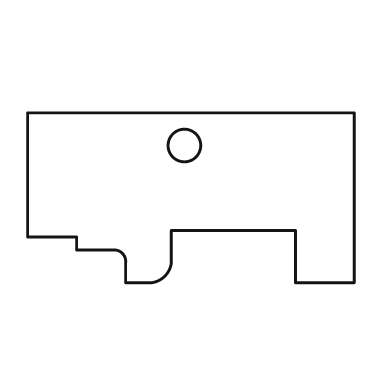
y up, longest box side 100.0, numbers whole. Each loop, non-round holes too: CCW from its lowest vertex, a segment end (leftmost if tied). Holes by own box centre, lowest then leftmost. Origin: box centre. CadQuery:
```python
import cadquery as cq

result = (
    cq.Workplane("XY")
    .moveTo(-20.0, -26.0)
    .lineTo(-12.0, -26.0)
    .threePointArc((-8.0, -24.0), (-6.0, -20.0))
    .lineTo(-6.0, -10.0)
    .lineTo(32.0, -10.0)
    .lineTo(32.0, -26.0)
    .lineTo(50.0, -26.0)
    .lineTo(50.0, 26.0)
    .lineTo(-50.0, 26.0)
    .lineTo(-50.0, -12.0)
    .lineTo(-35.0, -12.0)
    .lineTo(-35.0, -16.0)
    .lineTo(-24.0, -16.0)
    .threePointArc((-21.0, -17.0), (-20.0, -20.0))
    .close()
    .moveTo(-2.0, 16.0)
    .circle(5.0)
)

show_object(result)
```